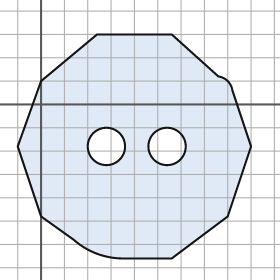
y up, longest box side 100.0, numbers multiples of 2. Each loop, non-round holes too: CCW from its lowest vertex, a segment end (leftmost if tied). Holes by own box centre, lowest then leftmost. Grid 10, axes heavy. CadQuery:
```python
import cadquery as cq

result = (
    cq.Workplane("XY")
    .moveTo(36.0, -66.0)
    .lineTo(56.0, -66.0)
    .lineTo(80.0, -48.0)
    .lineTo(90.0, -18.0)
    .lineTo(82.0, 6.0)
    .threePointArc((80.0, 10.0), (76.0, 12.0))
    .lineTo(56.0, 30.0)
    .lineTo(24.0, 30.0)
    .lineTo(0.0, 10.0)
    .lineTo(-10.0, -18.0)
    .lineTo(0.0, -48.0)
    .lineTo(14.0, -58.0)
    .threePointArc((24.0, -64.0), (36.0, -66.0))
    .close()
    .moveTo(28.0, -18.0)
    .circle(8.0)
    .moveTo(54.0, -18.0)
    .circle(8.0)
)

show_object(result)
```